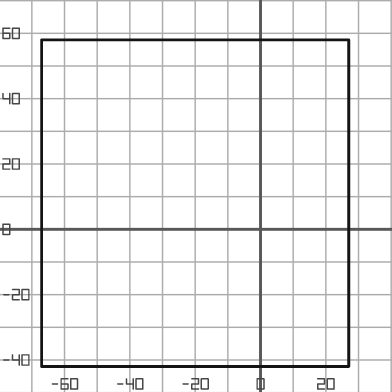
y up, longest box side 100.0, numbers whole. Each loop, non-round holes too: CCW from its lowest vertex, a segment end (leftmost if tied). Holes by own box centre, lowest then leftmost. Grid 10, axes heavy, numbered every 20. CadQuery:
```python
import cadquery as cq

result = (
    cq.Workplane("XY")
    .moveTo(-67.0, -42.0)
    .lineTo(27.0, -42.0)
    .lineTo(27.0, 58.0)
    .lineTo(-67.0, 58.0)
    .close()
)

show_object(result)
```